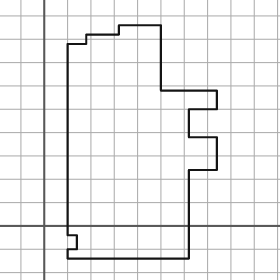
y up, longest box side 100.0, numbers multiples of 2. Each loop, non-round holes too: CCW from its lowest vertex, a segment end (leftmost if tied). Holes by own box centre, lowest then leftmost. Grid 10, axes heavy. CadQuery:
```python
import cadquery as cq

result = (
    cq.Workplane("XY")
    .moveTo(10.0, -14.0)
    .lineTo(62.0, -14.0)
    .lineTo(62.0, 24.0)
    .lineTo(74.0, 24.0)
    .lineTo(74.0, 38.0)
    .lineTo(62.0, 38.0)
    .lineTo(62.0, 50.0)
    .lineTo(74.0, 50.0)
    .lineTo(74.0, 58.0)
    .lineTo(50.0, 58.0)
    .lineTo(50.0, 86.0)
    .lineTo(32.0, 86.0)
    .lineTo(32.0, 82.0)
    .lineTo(18.0, 82.0)
    .lineTo(18.0, 78.0)
    .lineTo(10.0, 78.0)
    .lineTo(10.0, -4.0)
    .lineTo(14.0, -4.0)
    .lineTo(14.0, -10.0)
    .lineTo(10.0, -10.0)
    .close()
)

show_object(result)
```